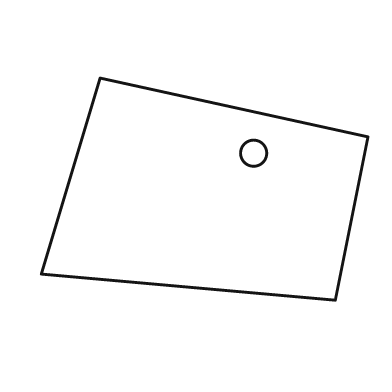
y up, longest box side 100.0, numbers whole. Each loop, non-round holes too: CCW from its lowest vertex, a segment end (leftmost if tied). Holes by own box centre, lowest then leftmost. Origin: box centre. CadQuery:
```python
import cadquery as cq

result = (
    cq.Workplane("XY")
    .moveTo(40.0, -34.0)
    .lineTo(50.0, 16.0)
    .lineTo(-32.0, 34.0)
    .lineTo(-50.0, -26.0)
    .close()
    .moveTo(15.0, 11.0)
    .circle(4.0)
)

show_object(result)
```